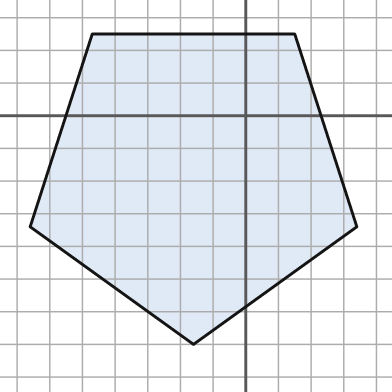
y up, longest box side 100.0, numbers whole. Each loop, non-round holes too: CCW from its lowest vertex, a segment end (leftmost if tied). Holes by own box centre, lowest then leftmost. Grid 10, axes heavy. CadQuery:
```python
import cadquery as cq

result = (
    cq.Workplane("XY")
    .moveTo(-16.0, -70.0)
    .lineTo(34.0, -34.0)
    .lineTo(15.0, 25.0)
    .lineTo(-47.0, 25.0)
    .lineTo(-66.0, -34.0)
    .close()
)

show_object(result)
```